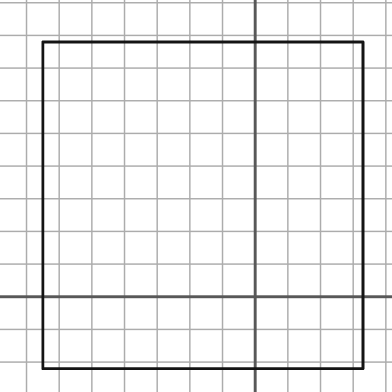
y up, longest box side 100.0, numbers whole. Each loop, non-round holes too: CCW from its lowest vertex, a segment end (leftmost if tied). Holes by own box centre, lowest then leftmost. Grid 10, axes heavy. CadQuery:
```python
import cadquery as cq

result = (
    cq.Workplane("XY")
    .moveTo(-65.0, -22.0)
    .lineTo(33.0, -22.0)
    .lineTo(33.0, 78.0)
    .lineTo(-65.0, 78.0)
    .close()
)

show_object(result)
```